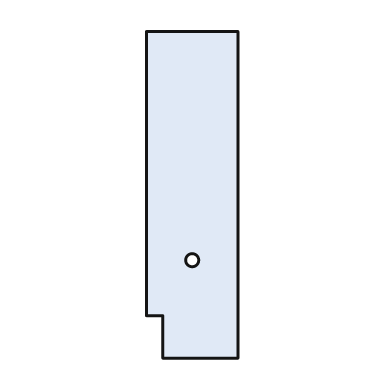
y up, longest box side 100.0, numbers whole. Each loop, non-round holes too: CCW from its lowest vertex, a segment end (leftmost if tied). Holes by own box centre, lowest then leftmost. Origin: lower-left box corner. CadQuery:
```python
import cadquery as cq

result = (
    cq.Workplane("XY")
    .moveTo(5.0, 0.0)
    .lineTo(28.0, 0.0)
    .lineTo(28.0, 100.0)
    .lineTo(0.0, 100.0)
    .lineTo(0.0, 13.0)
    .lineTo(5.0, 13.0)
    .close()
    .moveTo(14.0, 30.0)
    .circle(2.0)
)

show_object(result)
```